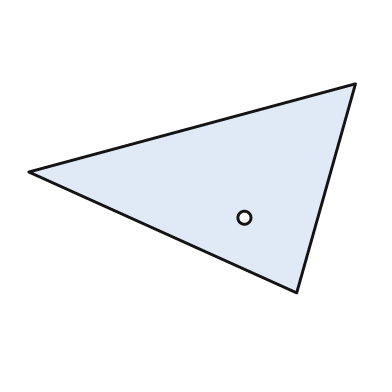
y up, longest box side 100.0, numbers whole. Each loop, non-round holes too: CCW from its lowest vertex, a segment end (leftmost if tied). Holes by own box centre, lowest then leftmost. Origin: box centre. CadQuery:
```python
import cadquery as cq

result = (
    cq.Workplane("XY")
    .moveTo(32.0, -32.0)
    .lineTo(50.0, 32.0)
    .lineTo(-50.0, 5.0)
    .close()
    .moveTo(16.0, -9.0)
    .circle(2.0)
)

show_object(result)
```